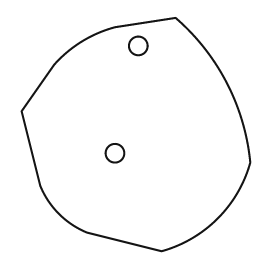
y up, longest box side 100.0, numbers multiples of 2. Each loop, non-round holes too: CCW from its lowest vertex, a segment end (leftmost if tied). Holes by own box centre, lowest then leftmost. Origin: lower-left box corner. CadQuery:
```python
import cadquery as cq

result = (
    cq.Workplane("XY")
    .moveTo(60.0, 0.0)
    .threePointArc((84.0, 14.0), (98.0, 38.0))
    .threePointArc((88.0, 72.0), (66.0, 100.0))
    .lineTo(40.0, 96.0)
    .threePointArc((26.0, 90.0), (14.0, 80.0))
    .lineTo(0.0, 60.0)
    .lineTo(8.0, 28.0)
    .threePointArc((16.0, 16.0), (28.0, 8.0))
    .close()
    .moveTo(40.0, 42.0)
    .circle(4.0)
    .moveTo(50.0, 88.0)
    .circle(4.0)
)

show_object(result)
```